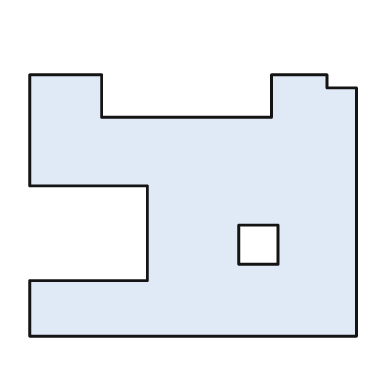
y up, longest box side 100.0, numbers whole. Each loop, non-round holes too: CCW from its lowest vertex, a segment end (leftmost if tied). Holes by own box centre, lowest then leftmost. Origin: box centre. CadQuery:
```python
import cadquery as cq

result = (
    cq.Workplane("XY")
    .moveTo(-50.0, -40.0)
    .lineTo(50.0, -40.0)
    .lineTo(50.0, 36.0)
    .lineTo(41.0, 36.0)
    .lineTo(41.0, 40.0)
    .lineTo(24.0, 40.0)
    .lineTo(24.0, 27.0)
    .lineTo(-28.0, 27.0)
    .lineTo(-28.0, 40.0)
    .lineTo(-50.0, 40.0)
    .lineTo(-50.0, 6.0)
    .lineTo(-14.0, 6.0)
    .lineTo(-14.0, -23.0)
    .lineTo(-50.0, -23.0)
    .close()
    .moveTo(14.0, -18.0)
    .lineTo(26.0, -18.0)
    .lineTo(26.0, -6.0)
    .lineTo(14.0, -6.0)
    .close()
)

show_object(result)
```